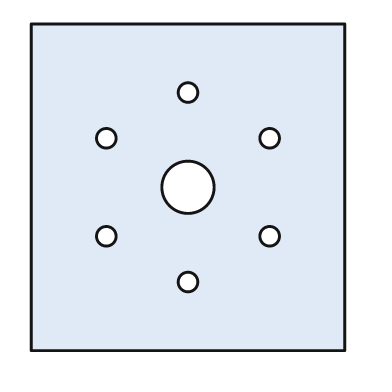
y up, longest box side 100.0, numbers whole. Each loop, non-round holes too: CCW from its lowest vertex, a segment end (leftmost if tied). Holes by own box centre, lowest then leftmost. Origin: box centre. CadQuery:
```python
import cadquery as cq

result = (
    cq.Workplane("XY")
    .moveTo(-48.0, -50.0)
    .lineTo(48.0, -50.0)
    .lineTo(48.0, 50.0)
    .lineTo(-48.0, 50.0)
    .close()
    .moveTo(0.0, -29.0)
    .circle(3.0)
    .moveTo(-25.0, -15.0)
    .circle(3.0)
    .moveTo(25.0, -15.0)
    .circle(3.0)
    .moveTo(0.0, 0.0)
    .circle(8.0)
    .moveTo(-25.0, 15.0)
    .circle(3.0)
    .moveTo(25.0, 15.0)
    .circle(3.0)
    .moveTo(0.0, 29.0)
    .circle(3.0)
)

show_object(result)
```